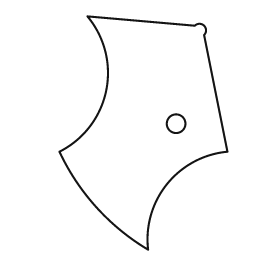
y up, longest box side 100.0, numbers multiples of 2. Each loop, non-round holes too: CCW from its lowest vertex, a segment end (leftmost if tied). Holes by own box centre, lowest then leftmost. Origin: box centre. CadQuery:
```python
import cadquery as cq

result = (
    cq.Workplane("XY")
    .moveTo(2.0, -50.0)
    .threePointArc((10.0, -22.0), (36.0, -8.0))
    .lineTo(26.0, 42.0)
    .threePointArc((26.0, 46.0), (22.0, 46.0))
    .lineTo(-24.0, 50.0)
    .threePointArc((-16.0, 18.0), (-36.0, -8.0))
    .threePointArc((-20.0, -32.0), (2.0, -50.0))
    .close()
    .moveTo(14.0, 4.0)
    .circle(4.0)
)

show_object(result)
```